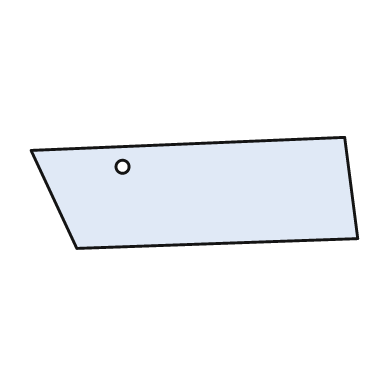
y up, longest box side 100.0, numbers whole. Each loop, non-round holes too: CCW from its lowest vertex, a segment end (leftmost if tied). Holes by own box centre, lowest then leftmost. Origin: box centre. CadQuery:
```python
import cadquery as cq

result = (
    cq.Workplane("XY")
    .moveTo(-36.0, -17.0)
    .lineTo(50.0, -14.0)
    .lineTo(46.0, 17.0)
    .lineTo(-50.0, 13.0)
    .close()
    .moveTo(-22.0, 8.0)
    .circle(2.0)
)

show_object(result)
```